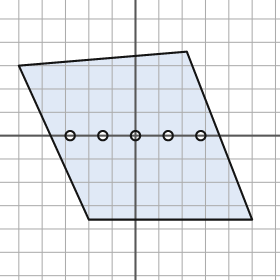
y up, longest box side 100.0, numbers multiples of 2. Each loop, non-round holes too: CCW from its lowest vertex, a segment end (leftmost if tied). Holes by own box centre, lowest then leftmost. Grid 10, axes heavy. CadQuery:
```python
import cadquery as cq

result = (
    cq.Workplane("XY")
    .moveTo(-20.0, -36.0)
    .lineTo(50.0, -36.0)
    .lineTo(22.0, 36.0)
    .lineTo(-50.0, 30.0)
    .close()
    .moveTo(-28.0, 0.0)
    .circle(2.0)
    .moveTo(-14.0, 0.0)
    .circle(2.0)
    .moveTo(0.0, 0.0)
    .circle(2.0)
    .moveTo(14.0, 0.0)
    .circle(2.0)
    .moveTo(28.0, 0.0)
    .circle(2.0)
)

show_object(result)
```